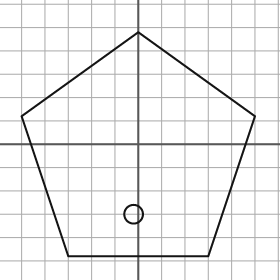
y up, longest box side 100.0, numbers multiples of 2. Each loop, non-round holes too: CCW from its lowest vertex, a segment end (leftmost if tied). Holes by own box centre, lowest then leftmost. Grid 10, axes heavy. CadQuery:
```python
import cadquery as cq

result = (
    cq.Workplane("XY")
    .moveTo(-30.0, -48.0)
    .lineTo(30.0, -48.0)
    .lineTo(50.0, 12.0)
    .lineTo(0.0, 48.0)
    .lineTo(-50.0, 12.0)
    .close()
    .moveTo(-2.0, -30.0)
    .circle(4.0)
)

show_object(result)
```